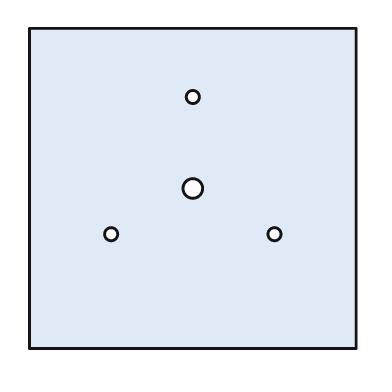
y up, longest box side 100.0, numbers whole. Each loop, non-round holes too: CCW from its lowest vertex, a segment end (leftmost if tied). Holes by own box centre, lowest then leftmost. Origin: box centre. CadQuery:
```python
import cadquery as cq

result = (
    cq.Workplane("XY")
    .moveTo(-50.0, -49.0)
    .lineTo(50.0, -49.0)
    .lineTo(50.0, 49.0)
    .lineTo(-50.0, 49.0)
    .close()
    .moveTo(-25.0, -14.0)
    .circle(2.0)
    .moveTo(25.0, -14.0)
    .circle(2.0)
    .moveTo(0.0, 0.0)
    .circle(3.0)
    .moveTo(0.0, 28.0)
    .circle(2.0)
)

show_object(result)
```